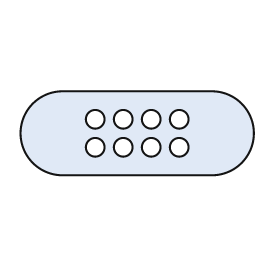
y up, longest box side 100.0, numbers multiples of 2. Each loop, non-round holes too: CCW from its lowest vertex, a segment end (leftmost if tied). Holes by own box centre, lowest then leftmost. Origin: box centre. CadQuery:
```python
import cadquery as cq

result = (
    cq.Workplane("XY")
    .moveTo(-32.0, -18.0)
    .lineTo(32.0, -18.0)
    .threePointArc((50.0, 0.0), (32.0, 18.0))
    .lineTo(-32.0, 18.0)
    .threePointArc((-50.0, 0.0), (-32.0, -18.0))
    .close()
    .moveTo(-18.0, -6.0)
    .circle(4.0)
    .moveTo(-6.0, -6.0)
    .circle(4.0)
    .moveTo(6.0, -6.0)
    .circle(4.0)
    .moveTo(18.0, -6.0)
    .circle(4.0)
    .moveTo(-18.0, 6.0)
    .circle(4.0)
    .moveTo(-6.0, 6.0)
    .circle(4.0)
    .moveTo(6.0, 6.0)
    .circle(4.0)
    .moveTo(18.0, 6.0)
    .circle(4.0)
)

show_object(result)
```